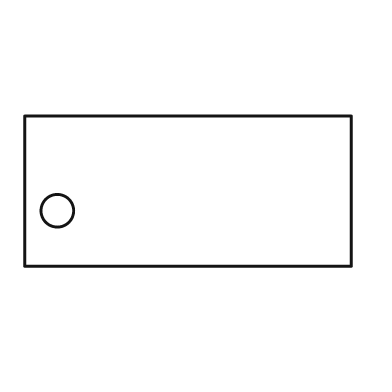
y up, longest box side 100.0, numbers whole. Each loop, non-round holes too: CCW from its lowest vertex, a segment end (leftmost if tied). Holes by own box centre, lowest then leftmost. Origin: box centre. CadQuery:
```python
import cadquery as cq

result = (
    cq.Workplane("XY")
    .moveTo(-50.0, -23.0)
    .lineTo(50.0, -23.0)
    .lineTo(50.0, 23.0)
    .lineTo(-50.0, 23.0)
    .close()
    .moveTo(-40.0, -6.0)
    .circle(5.0)
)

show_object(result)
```